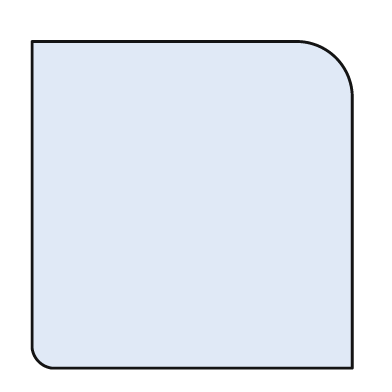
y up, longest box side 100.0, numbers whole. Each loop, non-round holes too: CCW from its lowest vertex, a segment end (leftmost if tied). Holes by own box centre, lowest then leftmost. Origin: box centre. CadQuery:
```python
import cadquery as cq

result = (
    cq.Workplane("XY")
    .moveTo(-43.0, -50.0)
    .lineTo(49.0, -50.0)
    .lineTo(49.0, 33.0)
    .threePointArc((44.0, 45.0), (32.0, 50.0))
    .lineTo(-49.0, 50.0)
    .lineTo(-49.0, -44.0)
    .threePointArc((-47.0, -48.0), (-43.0, -50.0))
    .close()
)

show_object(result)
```